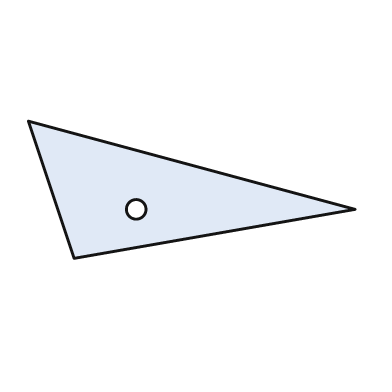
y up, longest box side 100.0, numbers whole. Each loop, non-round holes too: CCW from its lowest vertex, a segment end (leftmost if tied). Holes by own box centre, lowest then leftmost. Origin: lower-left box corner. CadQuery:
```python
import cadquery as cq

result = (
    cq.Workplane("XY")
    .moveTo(14.0, 0.0)
    .lineTo(100.0, 15.0)
    .lineTo(0.0, 42.0)
    .close()
    .moveTo(33.0, 15.0)
    .circle(3.0)
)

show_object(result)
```